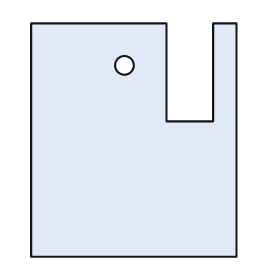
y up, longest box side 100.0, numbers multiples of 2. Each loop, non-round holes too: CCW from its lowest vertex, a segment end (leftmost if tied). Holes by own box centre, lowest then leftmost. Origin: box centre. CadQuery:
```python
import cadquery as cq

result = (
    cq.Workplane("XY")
    .moveTo(-44.0, -50.0)
    .lineTo(44.0, -50.0)
    .lineTo(44.0, 50.0)
    .lineTo(34.0, 50.0)
    .lineTo(34.0, 8.0)
    .lineTo(14.0, 8.0)
    .lineTo(14.0, 50.0)
    .lineTo(-44.0, 50.0)
    .close()
    .moveTo(-4.0, 32.0)
    .circle(4.0)
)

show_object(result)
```